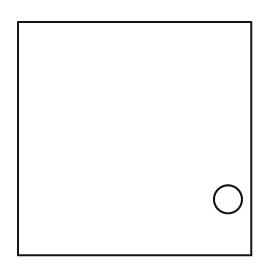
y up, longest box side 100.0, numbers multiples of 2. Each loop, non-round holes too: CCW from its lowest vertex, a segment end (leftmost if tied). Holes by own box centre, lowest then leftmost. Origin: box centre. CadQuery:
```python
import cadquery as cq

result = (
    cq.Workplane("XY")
    .moveTo(-50.0, -50.0)
    .lineTo(50.0, -50.0)
    .lineTo(50.0, 50.0)
    .lineTo(-50.0, 50.0)
    .close()
    .moveTo(40.0, -26.0)
    .circle(6.0)
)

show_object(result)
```